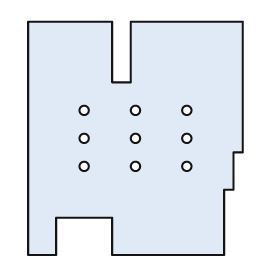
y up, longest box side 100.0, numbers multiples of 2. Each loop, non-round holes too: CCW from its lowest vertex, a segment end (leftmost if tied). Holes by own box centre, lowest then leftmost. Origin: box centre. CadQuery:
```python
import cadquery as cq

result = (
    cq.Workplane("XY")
    .moveTo(-46.0, -50.0)
    .lineTo(-34.0, -50.0)
    .lineTo(-34.0, -34.0)
    .lineTo(-10.0, -34.0)
    .lineTo(-10.0, -50.0)
    .lineTo(38.0, -50.0)
    .lineTo(38.0, -22.0)
    .lineTo(42.0, -22.0)
    .lineTo(42.0, -6.0)
    .lineTo(46.0, -6.0)
    .lineTo(46.0, 50.0)
    .lineTo(-2.0, 50.0)
    .lineTo(-2.0, 24.0)
    .lineTo(-10.0, 24.0)
    .lineTo(-10.0, 50.0)
    .lineTo(-46.0, 50.0)
    .close()
    .moveTo(-22.0, -12.0)
    .circle(2.0)
    .moveTo(0.0, -12.0)
    .circle(2.0)
    .moveTo(22.0, -12.0)
    .circle(2.0)
    .moveTo(-22.0, 0.0)
    .circle(2.0)
    .moveTo(0.0, 0.0)
    .circle(2.0)
    .moveTo(22.0, 0.0)
    .circle(2.0)
    .moveTo(-22.0, 12.0)
    .circle(2.0)
    .moveTo(0.0, 12.0)
    .circle(2.0)
    .moveTo(22.0, 12.0)
    .circle(2.0)
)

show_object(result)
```